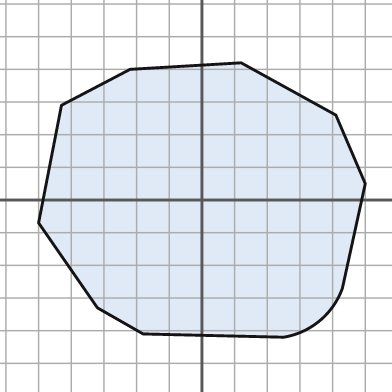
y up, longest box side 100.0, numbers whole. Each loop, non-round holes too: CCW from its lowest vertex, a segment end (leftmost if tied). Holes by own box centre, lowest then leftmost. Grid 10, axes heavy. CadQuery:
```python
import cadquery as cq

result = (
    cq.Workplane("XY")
    .moveTo(25.0, -42.0)
    .threePointArc((36.0, -37.0), (43.0, -27.0))
    .lineTo(50.0, 5.0)
    .lineTo(41.0, 26.0)
    .lineTo(12.0, 42.0)
    .lineTo(-22.0, 40.0)
    .lineTo(-43.0, 29.0)
    .lineTo(-50.0, -7.0)
    .lineTo(-32.0, -33.0)
    .lineTo(-18.0, -41.0)
    .close()
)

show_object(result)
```